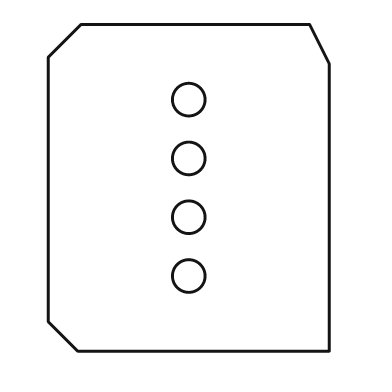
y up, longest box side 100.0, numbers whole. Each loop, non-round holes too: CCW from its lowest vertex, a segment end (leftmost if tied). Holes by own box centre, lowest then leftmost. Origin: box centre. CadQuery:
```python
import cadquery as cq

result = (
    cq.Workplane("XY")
    .moveTo(-34.0, -50.0)
    .lineTo(43.0, -50.0)
    .lineTo(43.0, 38.0)
    .lineTo(37.0, 50.0)
    .lineTo(-33.0, 50.0)
    .lineTo(-43.0, 40.0)
    .lineTo(-43.0, -41.0)
    .close()
    .moveTo(0.0, -27.0)
    .circle(5.0)
    .moveTo(0.0, -9.0)
    .circle(5.0)
    .moveTo(0.0, 9.0)
    .circle(5.0)
    .moveTo(0.0, 27.0)
    .circle(5.0)
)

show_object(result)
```